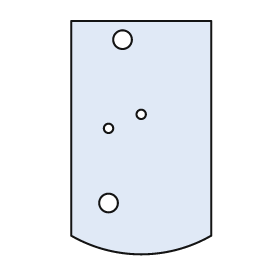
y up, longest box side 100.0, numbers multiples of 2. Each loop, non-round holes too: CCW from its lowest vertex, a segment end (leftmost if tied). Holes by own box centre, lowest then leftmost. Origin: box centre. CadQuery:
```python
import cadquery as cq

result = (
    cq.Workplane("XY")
    .moveTo(-30.0, -42.0)
    .threePointArc((0.0, -50.0), (30.0, -42.0))
    .lineTo(30.0, 50.0)
    .lineTo(-30.0, 50.0)
    .close()
    .moveTo(-14.0, -28.0)
    .circle(4.0)
    .moveTo(-14.0, 4.0)
    .circle(2.0)
    .moveTo(0.0, 10.0)
    .circle(2.0)
    .moveTo(-8.0, 42.0)
    .circle(4.0)
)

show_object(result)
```